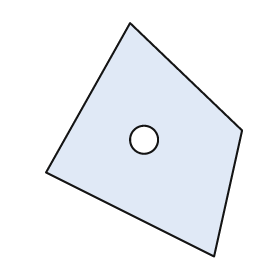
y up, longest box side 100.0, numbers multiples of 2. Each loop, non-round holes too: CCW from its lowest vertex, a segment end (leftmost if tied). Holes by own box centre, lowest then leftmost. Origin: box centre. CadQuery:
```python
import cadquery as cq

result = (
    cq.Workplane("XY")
    .moveTo(30.0, -50.0)
    .lineTo(42.0, 4.0)
    .lineTo(-6.0, 50.0)
    .lineTo(-42.0, -14.0)
    .close()
    .moveTo(0.0, 0.0)
    .circle(6.0)
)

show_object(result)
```